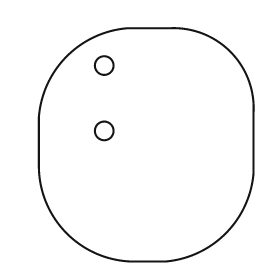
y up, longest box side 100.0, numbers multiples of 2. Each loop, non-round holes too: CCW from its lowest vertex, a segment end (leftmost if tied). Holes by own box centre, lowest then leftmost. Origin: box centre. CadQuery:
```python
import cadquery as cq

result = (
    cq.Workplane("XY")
    .moveTo(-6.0, -50.0)
    .lineTo(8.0, -50.0)
    .threePointArc((34.0, -38.0), (46.0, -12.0))
    .lineTo(46.0, 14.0)
    .threePointArc((36.0, 40.0), (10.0, 50.0))
    .lineTo(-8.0, 50.0)
    .threePointArc((-34.0, 38.0), (-46.0, 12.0))
    .lineTo(-46.0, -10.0)
    .threePointArc((-34.0, -38.0), (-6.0, -50.0))
    .close()
    .moveTo(-18.0, 6.0)
    .circle(4.0)
    .moveTo(-18.0, 34.0)
    .circle(4.0)
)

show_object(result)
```